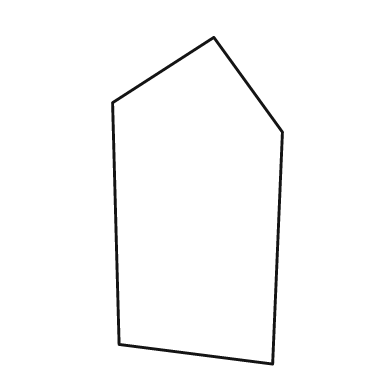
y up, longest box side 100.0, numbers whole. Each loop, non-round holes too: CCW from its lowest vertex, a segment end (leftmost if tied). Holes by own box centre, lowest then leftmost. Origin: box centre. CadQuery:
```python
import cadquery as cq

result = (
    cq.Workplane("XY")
    .moveTo(23.0, -50.0)
    .lineTo(26.0, 21.0)
    .lineTo(5.0, 50.0)
    .lineTo(-26.0, 30.0)
    .lineTo(-24.0, -44.0)
    .close()
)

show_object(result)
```